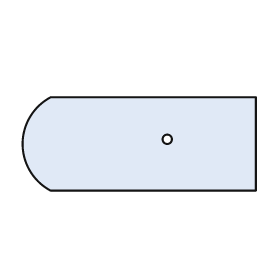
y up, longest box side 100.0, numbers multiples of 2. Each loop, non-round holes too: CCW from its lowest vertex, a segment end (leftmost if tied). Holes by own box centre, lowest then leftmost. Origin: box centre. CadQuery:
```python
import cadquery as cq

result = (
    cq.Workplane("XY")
    .moveTo(-38.0, -20.0)
    .lineTo(50.0, -20.0)
    .lineTo(50.0, 20.0)
    .lineTo(-38.0, 20.0)
    .threePointArc((-50.0, 0.0), (-38.0, -20.0))
    .close()
    .moveTo(12.0, 2.0)
    .circle(2.0)
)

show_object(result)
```